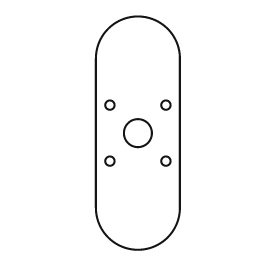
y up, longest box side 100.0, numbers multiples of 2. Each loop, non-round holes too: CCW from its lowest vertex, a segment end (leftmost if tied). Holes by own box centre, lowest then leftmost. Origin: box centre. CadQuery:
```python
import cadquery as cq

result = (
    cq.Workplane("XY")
    .moveTo(-18.0, -32.0)
    .threePointArc((0.0, -50.0), (18.0, -32.0))
    .lineTo(18.0, 32.0)
    .threePointArc((0.0, 50.0), (-18.0, 32.0))
    .close()
    .moveTo(-12.0, -12.0)
    .circle(2.0)
    .moveTo(12.0, -12.0)
    .circle(2.0)
    .moveTo(0.0, 0.0)
    .circle(6.0)
    .moveTo(-12.0, 12.0)
    .circle(2.0)
    .moveTo(12.0, 12.0)
    .circle(2.0)
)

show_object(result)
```